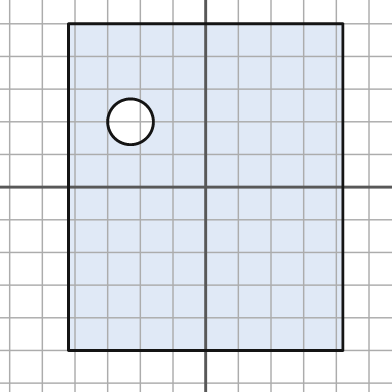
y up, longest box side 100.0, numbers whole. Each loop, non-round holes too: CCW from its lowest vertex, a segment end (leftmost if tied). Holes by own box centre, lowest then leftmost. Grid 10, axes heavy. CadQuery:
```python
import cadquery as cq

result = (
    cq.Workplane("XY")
    .moveTo(-42.0, -50.0)
    .lineTo(42.0, -50.0)
    .lineTo(42.0, 50.0)
    .lineTo(-42.0, 50.0)
    .close()
    .moveTo(-23.0, 20.0)
    .circle(7.0)
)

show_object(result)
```